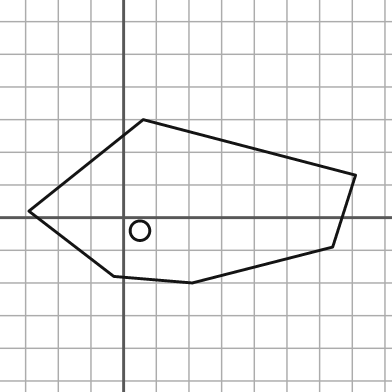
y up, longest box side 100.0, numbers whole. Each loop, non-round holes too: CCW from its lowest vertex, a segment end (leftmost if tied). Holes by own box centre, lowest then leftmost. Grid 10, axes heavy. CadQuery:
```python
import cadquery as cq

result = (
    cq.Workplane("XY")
    .moveTo(21.0, -20.0)
    .lineTo(64.0, -9.0)
    .lineTo(71.0, 13.0)
    .lineTo(6.0, 30.0)
    .lineTo(-29.0, 2.0)
    .lineTo(-3.0, -18.0)
    .close()
    .moveTo(5.0, -4.0)
    .circle(3.0)
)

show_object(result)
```